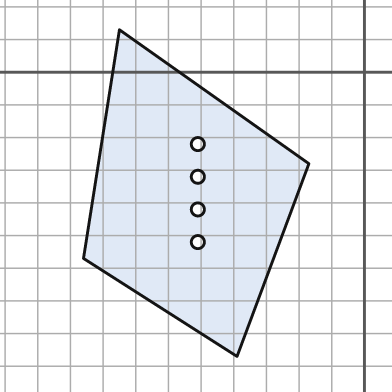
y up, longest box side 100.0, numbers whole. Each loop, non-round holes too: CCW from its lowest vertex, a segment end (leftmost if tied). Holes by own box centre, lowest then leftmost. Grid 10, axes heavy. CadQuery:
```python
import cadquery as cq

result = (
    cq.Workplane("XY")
    .moveTo(-39.0, -87.0)
    .lineTo(-17.0, -28.0)
    .lineTo(-75.0, 13.0)
    .lineTo(-86.0, -57.0)
    .close()
    .moveTo(-51.0, -52.0)
    .circle(2.0)
    .moveTo(-51.0, -42.0)
    .circle(2.0)
    .moveTo(-51.0, -32.0)
    .circle(2.0)
    .moveTo(-51.0, -22.0)
    .circle(2.0)
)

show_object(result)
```